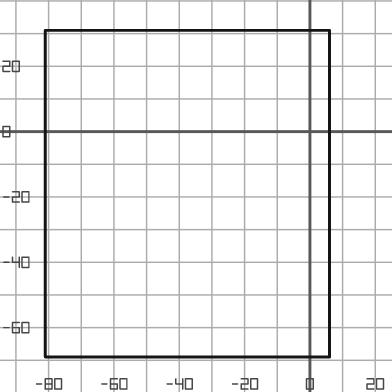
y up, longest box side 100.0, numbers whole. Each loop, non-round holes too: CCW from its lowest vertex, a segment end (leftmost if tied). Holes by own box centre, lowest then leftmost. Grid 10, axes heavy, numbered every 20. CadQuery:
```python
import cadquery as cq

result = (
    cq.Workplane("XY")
    .moveTo(-81.0, -69.0)
    .lineTo(6.0, -69.0)
    .lineTo(6.0, 31.0)
    .lineTo(-81.0, 31.0)
    .close()
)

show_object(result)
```